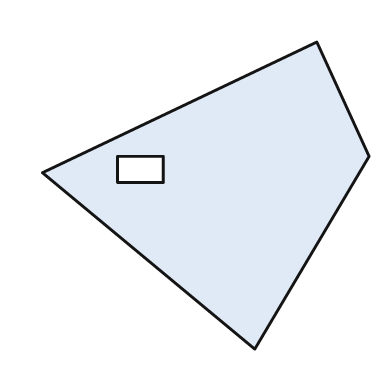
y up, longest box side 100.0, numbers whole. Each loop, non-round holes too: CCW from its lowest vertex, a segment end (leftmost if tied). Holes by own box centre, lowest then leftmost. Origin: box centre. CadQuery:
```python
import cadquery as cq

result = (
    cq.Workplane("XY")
    .moveTo(15.0, -47.0)
    .lineTo(50.0, 12.0)
    .lineTo(34.0, 47.0)
    .lineTo(-50.0, 7.0)
    .close()
    .moveTo(-27.0, 4.0)
    .lineTo(-13.0, 4.0)
    .lineTo(-13.0, 12.0)
    .lineTo(-27.0, 12.0)
    .close()
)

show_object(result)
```